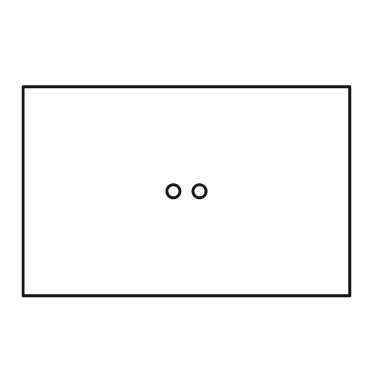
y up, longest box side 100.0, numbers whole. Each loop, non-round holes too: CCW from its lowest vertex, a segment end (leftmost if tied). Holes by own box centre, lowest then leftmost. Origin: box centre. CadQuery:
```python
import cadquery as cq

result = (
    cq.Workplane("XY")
    .moveTo(-50.0, -32.0)
    .lineTo(50.0, -32.0)
    .lineTo(50.0, 32.0)
    .lineTo(-50.0, 32.0)
    .close()
    .moveTo(-4.0, 0.0)
    .circle(2.0)
    .moveTo(4.0, 0.0)
    .circle(2.0)
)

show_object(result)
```